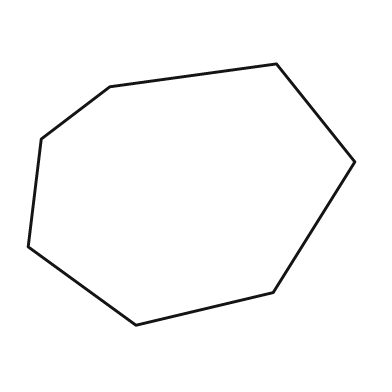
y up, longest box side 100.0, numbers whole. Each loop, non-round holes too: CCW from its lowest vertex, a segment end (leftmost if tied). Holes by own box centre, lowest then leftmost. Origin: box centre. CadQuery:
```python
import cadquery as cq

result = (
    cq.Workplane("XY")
    .moveTo(-17.0, -40.0)
    .lineTo(25.0, -30.0)
    .lineTo(50.0, 10.0)
    .lineTo(26.0, 40.0)
    .lineTo(-25.0, 33.0)
    .lineTo(-46.0, 17.0)
    .lineTo(-50.0, -16.0)
    .close()
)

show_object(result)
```